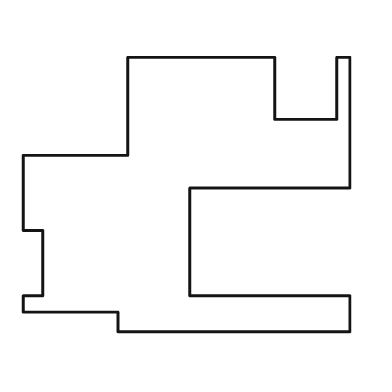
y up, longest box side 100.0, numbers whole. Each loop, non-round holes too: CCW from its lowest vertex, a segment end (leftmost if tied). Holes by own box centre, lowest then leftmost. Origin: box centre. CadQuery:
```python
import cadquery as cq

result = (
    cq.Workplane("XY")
    .moveTo(-21.0, -42.0)
    .lineTo(50.0, -42.0)
    .lineTo(50.0, -31.0)
    .lineTo(1.0, -31.0)
    .lineTo(1.0, 2.0)
    .lineTo(50.0, 2.0)
    .lineTo(50.0, 42.0)
    .lineTo(46.0, 42.0)
    .lineTo(46.0, 23.0)
    .lineTo(27.0, 23.0)
    .lineTo(27.0, 42.0)
    .lineTo(-18.0, 42.0)
    .lineTo(-18.0, 12.0)
    .lineTo(-50.0, 12.0)
    .lineTo(-50.0, -11.0)
    .lineTo(-44.0, -11.0)
    .lineTo(-44.0, -31.0)
    .lineTo(-50.0, -31.0)
    .lineTo(-50.0, -36.0)
    .lineTo(-21.0, -36.0)
    .close()
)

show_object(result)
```